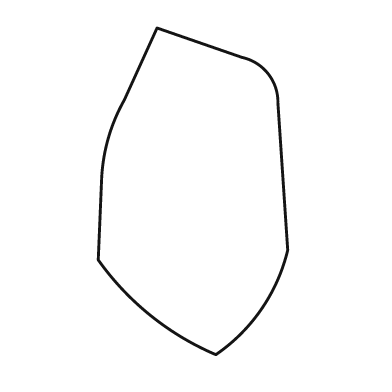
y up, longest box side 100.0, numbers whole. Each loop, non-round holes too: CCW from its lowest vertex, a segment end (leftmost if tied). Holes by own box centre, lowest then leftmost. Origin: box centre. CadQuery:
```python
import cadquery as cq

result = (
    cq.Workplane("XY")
    .moveTo(7.0, -50.0)
    .threePointArc((21.0, -36.0), (29.0, -18.0))
    .lineTo(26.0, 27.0)
    .threePointArc((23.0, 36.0), (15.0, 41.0))
    .lineTo(-11.0, 50.0)
    .lineTo(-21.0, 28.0)
    .threePointArc((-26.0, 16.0), (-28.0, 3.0))
    .lineTo(-29.0, -21.0)
    .threePointArc((-13.0, -38.0), (7.0, -50.0))
    .close()
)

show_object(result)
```